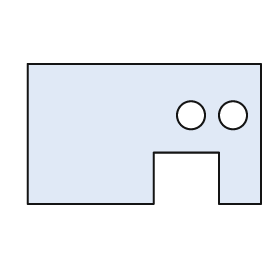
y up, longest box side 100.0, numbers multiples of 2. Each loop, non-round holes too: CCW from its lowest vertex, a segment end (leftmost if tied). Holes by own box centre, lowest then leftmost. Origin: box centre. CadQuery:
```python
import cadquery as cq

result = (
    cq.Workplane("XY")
    .moveTo(-50.0, -30.0)
    .lineTo(4.0, -30.0)
    .lineTo(4.0, -8.0)
    .lineTo(32.0, -8.0)
    .lineTo(32.0, -30.0)
    .lineTo(50.0, -30.0)
    .lineTo(50.0, 30.0)
    .lineTo(-50.0, 30.0)
    .close()
    .moveTo(20.0, 8.0)
    .circle(6.0)
    .moveTo(38.0, 8.0)
    .circle(6.0)
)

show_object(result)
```